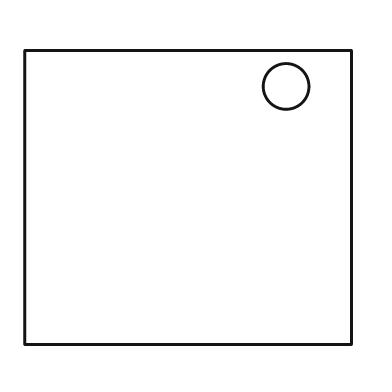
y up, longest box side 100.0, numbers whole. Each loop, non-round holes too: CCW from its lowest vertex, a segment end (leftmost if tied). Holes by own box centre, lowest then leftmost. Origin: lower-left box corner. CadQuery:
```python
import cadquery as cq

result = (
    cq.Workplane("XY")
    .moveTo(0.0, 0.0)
    .lineTo(100.0, 0.0)
    .lineTo(100.0, 90.0)
    .lineTo(0.0, 90.0)
    .close()
    .moveTo(80.0, 79.0)
    .circle(7.0)
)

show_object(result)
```